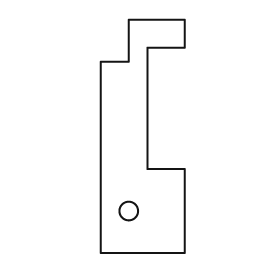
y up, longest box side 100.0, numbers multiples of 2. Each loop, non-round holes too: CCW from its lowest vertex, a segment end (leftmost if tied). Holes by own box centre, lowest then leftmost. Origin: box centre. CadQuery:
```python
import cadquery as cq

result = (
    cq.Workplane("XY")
    .moveTo(-18.0, -50.0)
    .lineTo(18.0, -50.0)
    .lineTo(18.0, -14.0)
    .lineTo(2.0, -14.0)
    .lineTo(2.0, 38.0)
    .lineTo(18.0, 38.0)
    .lineTo(18.0, 50.0)
    .lineTo(-6.0, 50.0)
    .lineTo(-6.0, 32.0)
    .lineTo(-18.0, 32.0)
    .close()
    .moveTo(-6.0, -32.0)
    .circle(4.0)
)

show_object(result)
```